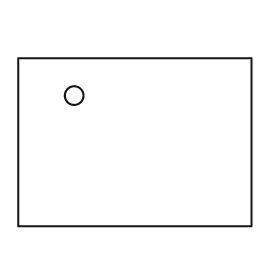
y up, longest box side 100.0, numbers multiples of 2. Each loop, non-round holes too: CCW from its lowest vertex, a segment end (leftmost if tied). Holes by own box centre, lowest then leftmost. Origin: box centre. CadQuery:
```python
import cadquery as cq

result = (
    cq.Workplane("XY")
    .moveTo(-50.0, -36.0)
    .lineTo(50.0, -36.0)
    .lineTo(50.0, 36.0)
    .lineTo(-50.0, 36.0)
    .close()
    .moveTo(-26.0, 20.0)
    .circle(4.0)
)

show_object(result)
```